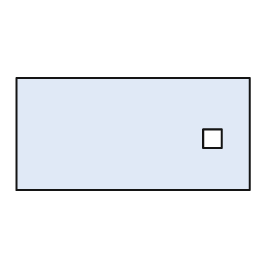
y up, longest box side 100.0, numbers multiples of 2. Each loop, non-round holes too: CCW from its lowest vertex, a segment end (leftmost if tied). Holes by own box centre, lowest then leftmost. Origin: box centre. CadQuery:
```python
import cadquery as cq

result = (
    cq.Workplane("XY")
    .moveTo(-50.0, -24.0)
    .lineTo(50.0, -24.0)
    .lineTo(50.0, 24.0)
    .lineTo(-50.0, 24.0)
    .close()
    .moveTo(30.0, -6.0)
    .lineTo(38.0, -6.0)
    .lineTo(38.0, 2.0)
    .lineTo(30.0, 2.0)
    .close()
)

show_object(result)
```